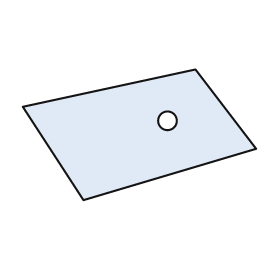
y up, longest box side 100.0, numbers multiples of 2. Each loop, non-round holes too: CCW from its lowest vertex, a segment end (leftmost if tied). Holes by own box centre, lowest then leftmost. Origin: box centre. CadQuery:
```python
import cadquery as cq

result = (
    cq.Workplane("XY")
    .moveTo(-24.0, -28.0)
    .lineTo(50.0, -6.0)
    .lineTo(24.0, 28.0)
    .lineTo(-50.0, 12.0)
    .close()
    .moveTo(12.0, 6.0)
    .circle(4.0)
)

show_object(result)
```